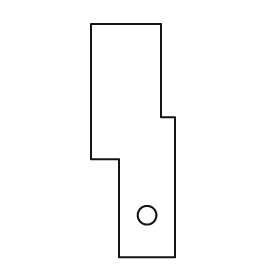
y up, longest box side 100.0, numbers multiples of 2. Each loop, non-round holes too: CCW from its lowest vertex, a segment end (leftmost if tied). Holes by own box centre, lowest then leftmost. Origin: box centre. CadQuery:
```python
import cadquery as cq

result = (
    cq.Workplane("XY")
    .moveTo(-6.0, -50.0)
    .lineTo(18.0, -50.0)
    .lineTo(18.0, 10.0)
    .lineTo(12.0, 10.0)
    .lineTo(12.0, 50.0)
    .lineTo(-18.0, 50.0)
    .lineTo(-18.0, -8.0)
    .lineTo(-6.0, -8.0)
    .close()
    .moveTo(6.0, -32.0)
    .circle(4.0)
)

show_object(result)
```